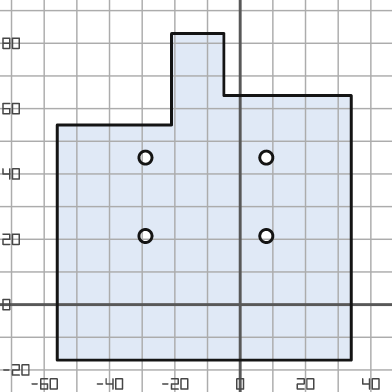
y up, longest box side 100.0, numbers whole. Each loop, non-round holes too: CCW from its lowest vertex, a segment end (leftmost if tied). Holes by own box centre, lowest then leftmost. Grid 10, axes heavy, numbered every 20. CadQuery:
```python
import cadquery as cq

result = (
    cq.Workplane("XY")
    .moveTo(-56.0, -17.0)
    .lineTo(34.0, -17.0)
    .lineTo(34.0, 64.0)
    .lineTo(-5.0, 64.0)
    .lineTo(-5.0, 83.0)
    .lineTo(-21.0, 83.0)
    .lineTo(-21.0, 55.0)
    .lineTo(-56.0, 55.0)
    .close()
    .moveTo(-29.0, 21.0)
    .circle(2.0)
    .moveTo(8.0, 21.0)
    .circle(2.0)
    .moveTo(-29.0, 45.0)
    .circle(2.0)
    .moveTo(8.0, 45.0)
    .circle(2.0)
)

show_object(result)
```